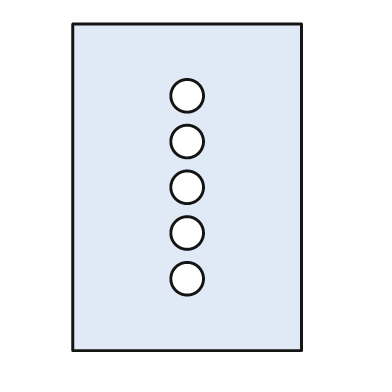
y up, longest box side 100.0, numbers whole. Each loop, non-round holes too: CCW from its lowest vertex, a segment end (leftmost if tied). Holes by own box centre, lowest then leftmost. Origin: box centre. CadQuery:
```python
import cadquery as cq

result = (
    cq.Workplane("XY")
    .moveTo(-35.0, -50.0)
    .lineTo(35.0, -50.0)
    .lineTo(35.0, 50.0)
    .lineTo(-35.0, 50.0)
    .close()
    .moveTo(0.0, -28.0)
    .circle(5.0)
    .moveTo(0.0, -14.0)
    .circle(5.0)
    .moveTo(0.0, 0.0)
    .circle(5.0)
    .moveTo(0.0, 14.0)
    .circle(5.0)
    .moveTo(0.0, 28.0)
    .circle(5.0)
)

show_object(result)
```